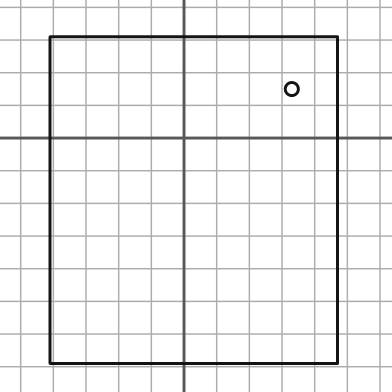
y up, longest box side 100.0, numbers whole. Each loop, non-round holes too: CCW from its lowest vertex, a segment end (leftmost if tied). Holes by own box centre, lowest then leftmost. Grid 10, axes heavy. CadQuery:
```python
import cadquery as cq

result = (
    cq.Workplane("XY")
    .moveTo(-41.0, -69.0)
    .lineTo(47.0, -69.0)
    .lineTo(47.0, 31.0)
    .lineTo(-41.0, 31.0)
    .close()
    .moveTo(33.0, 15.0)
    .circle(2.0)
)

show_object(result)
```